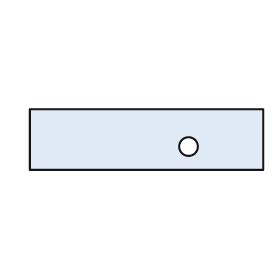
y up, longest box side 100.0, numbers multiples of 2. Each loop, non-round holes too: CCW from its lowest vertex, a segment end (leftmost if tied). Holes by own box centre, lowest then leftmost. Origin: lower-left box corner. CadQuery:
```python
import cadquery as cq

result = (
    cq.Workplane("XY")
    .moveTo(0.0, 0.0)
    .lineTo(100.0, 0.0)
    .lineTo(100.0, 26.0)
    .lineTo(0.0, 26.0)
    .close()
    .moveTo(68.0, 10.0)
    .circle(4.0)
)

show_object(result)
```